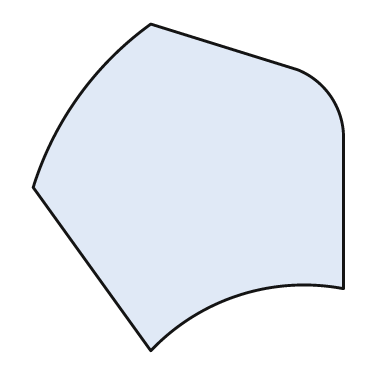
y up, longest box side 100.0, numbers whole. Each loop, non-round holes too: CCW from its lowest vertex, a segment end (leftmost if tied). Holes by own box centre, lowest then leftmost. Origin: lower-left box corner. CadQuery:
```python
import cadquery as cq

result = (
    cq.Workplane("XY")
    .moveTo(36.0, 0.0)
    .threePointArc((63.0, 17.0), (95.0, 19.0))
    .lineTo(95.0, 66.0)
    .threePointArc((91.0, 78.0), (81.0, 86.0))
    .lineTo(36.0, 100.0)
    .threePointArc((14.0, 78.0), (0.0, 50.0))
    .close()
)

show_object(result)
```